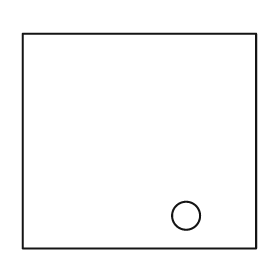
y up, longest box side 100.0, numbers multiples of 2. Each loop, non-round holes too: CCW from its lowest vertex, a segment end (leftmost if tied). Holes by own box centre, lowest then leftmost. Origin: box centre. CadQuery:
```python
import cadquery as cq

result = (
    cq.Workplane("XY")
    .moveTo(-50.0, -46.0)
    .lineTo(50.0, -46.0)
    .lineTo(50.0, 46.0)
    .lineTo(-50.0, 46.0)
    .close()
    .moveTo(20.0, -32.0)
    .circle(6.0)
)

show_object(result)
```